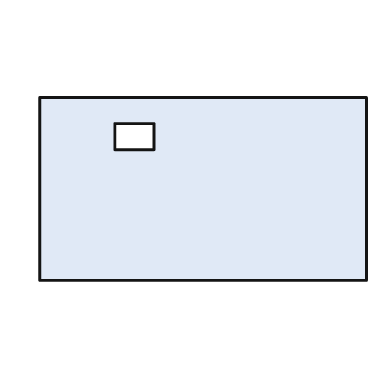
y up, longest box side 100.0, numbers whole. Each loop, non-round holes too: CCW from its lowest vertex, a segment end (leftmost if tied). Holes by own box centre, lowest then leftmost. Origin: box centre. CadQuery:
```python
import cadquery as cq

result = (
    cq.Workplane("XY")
    .moveTo(-50.0, -28.0)
    .lineTo(50.0, -28.0)
    .lineTo(50.0, 28.0)
    .lineTo(-50.0, 28.0)
    .close()
    .moveTo(-27.0, 12.0)
    .lineTo(-15.0, 12.0)
    .lineTo(-15.0, 20.0)
    .lineTo(-27.0, 20.0)
    .close()
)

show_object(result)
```